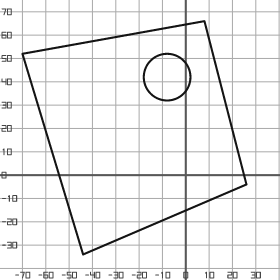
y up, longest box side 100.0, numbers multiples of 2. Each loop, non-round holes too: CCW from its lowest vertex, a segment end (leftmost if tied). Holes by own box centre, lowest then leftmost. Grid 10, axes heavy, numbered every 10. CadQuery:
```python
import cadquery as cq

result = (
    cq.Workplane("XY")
    .moveTo(-44.0, -34.0)
    .lineTo(26.0, -4.0)
    .lineTo(8.0, 66.0)
    .lineTo(-70.0, 52.0)
    .close()
    .moveTo(-8.0, 42.0)
    .circle(10.0)
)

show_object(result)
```